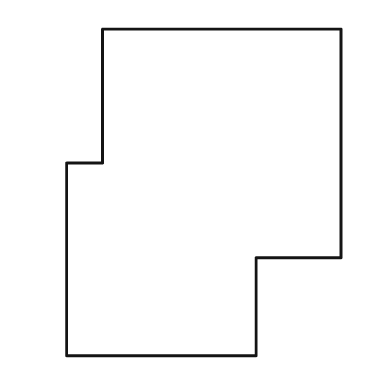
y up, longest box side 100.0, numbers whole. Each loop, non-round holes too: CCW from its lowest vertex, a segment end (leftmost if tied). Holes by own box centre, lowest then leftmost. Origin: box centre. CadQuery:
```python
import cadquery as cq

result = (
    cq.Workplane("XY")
    .moveTo(-42.0, -50.0)
    .lineTo(16.0, -50.0)
    .lineTo(16.0, -20.0)
    .lineTo(42.0, -20.0)
    .lineTo(42.0, 50.0)
    .lineTo(-31.0, 50.0)
    .lineTo(-31.0, 9.0)
    .lineTo(-42.0, 9.0)
    .close()
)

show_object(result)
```